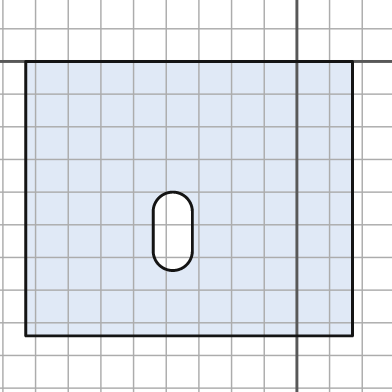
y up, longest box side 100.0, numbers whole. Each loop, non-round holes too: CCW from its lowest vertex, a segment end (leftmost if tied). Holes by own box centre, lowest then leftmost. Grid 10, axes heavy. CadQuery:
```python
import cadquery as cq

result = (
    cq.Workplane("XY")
    .moveTo(-83.0, -84.0)
    .lineTo(17.0, -84.0)
    .lineTo(17.0, 0.0)
    .lineTo(-83.0, 0.0)
    .close()
    .moveTo(-44.0, -58.0)
    .threePointArc((-38.0, -64.0), (-32.0, -58.0))
    .lineTo(-32.0, -46.0)
    .threePointArc((-38.0, -40.0), (-44.0, -46.0))
    .close()
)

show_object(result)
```